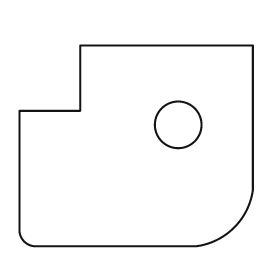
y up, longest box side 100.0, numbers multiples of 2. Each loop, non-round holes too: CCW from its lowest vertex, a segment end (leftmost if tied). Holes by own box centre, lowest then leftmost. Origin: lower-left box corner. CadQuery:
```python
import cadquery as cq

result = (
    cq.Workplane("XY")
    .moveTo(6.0, 0.0)
    .lineTo(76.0, 0.0)
    .threePointArc((92.0, 8.0), (100.0, 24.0))
    .lineTo(100.0, 86.0)
    .lineTo(26.0, 86.0)
    .lineTo(26.0, 58.0)
    .lineTo(0.0, 58.0)
    .lineTo(0.0, 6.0)
    .threePointArc((2.0, 2.0), (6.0, 0.0))
    .close()
    .moveTo(68.0, 52.0)
    .circle(10.0)
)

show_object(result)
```